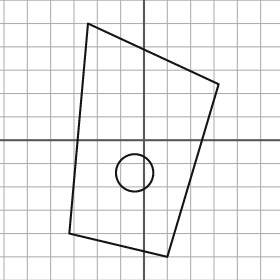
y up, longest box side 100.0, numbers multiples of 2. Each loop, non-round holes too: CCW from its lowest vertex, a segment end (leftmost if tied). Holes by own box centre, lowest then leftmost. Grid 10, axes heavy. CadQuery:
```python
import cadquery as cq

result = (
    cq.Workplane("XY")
    .moveTo(10.0, -50.0)
    .lineTo(32.0, 24.0)
    .lineTo(-24.0, 50.0)
    .lineTo(-32.0, -40.0)
    .close()
    .moveTo(-4.0, -14.0)
    .circle(8.0)
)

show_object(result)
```